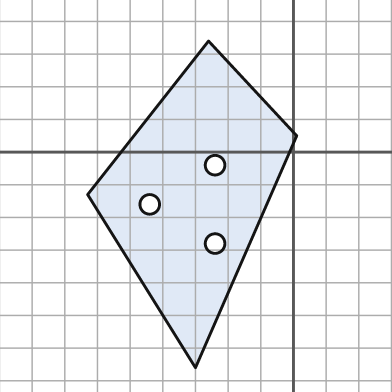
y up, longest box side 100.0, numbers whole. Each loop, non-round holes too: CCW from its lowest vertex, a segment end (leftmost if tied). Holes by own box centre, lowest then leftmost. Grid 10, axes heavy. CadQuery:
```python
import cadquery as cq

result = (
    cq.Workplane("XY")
    .moveTo(-30.0, -66.0)
    .lineTo(1.0, 5.0)
    .lineTo(-26.0, 34.0)
    .lineTo(-63.0, -13.0)
    .close()
    .moveTo(-24.0, -28.0)
    .circle(3.0)
    .moveTo(-44.0, -16.0)
    .circle(3.0)
    .moveTo(-24.0, -4.0)
    .circle(3.0)
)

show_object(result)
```